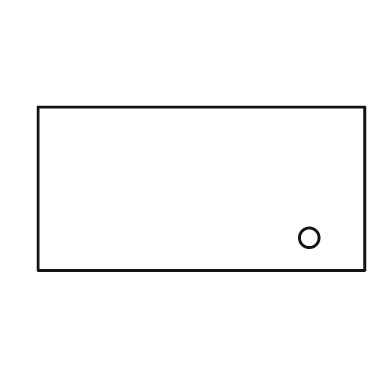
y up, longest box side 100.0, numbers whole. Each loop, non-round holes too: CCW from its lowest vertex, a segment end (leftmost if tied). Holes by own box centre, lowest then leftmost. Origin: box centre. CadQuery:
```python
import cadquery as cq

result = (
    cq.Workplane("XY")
    .moveTo(-50.0, -25.0)
    .lineTo(50.0, -25.0)
    .lineTo(50.0, 25.0)
    .lineTo(-50.0, 25.0)
    .close()
    .moveTo(33.0, -15.0)
    .circle(3.0)
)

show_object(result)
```